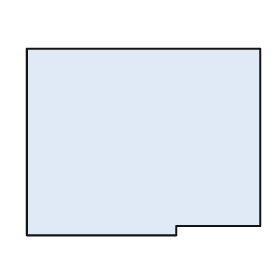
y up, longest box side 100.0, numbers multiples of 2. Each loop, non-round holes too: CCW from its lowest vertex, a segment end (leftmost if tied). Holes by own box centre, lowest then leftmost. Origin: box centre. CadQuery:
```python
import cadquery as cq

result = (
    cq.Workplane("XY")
    .moveTo(-50.0, -40.0)
    .lineTo(14.0, -40.0)
    .lineTo(14.0, -36.0)
    .lineTo(50.0, -36.0)
    .lineTo(50.0, 40.0)
    .lineTo(-50.0, 40.0)
    .close()
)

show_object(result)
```